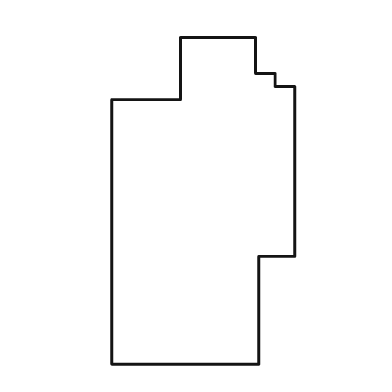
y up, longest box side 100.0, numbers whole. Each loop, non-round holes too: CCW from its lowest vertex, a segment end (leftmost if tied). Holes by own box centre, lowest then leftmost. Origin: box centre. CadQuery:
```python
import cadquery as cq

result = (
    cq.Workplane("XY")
    .moveTo(-28.0, -50.0)
    .lineTo(17.0, -50.0)
    .lineTo(17.0, -17.0)
    .lineTo(28.0, -17.0)
    .lineTo(28.0, 35.0)
    .lineTo(22.0, 35.0)
    .lineTo(22.0, 39.0)
    .lineTo(16.0, 39.0)
    .lineTo(16.0, 50.0)
    .lineTo(-7.0, 50.0)
    .lineTo(-7.0, 31.0)
    .lineTo(-28.0, 31.0)
    .close()
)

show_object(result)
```